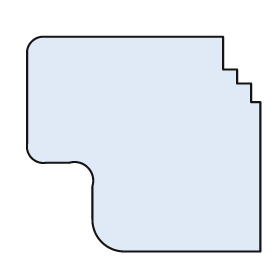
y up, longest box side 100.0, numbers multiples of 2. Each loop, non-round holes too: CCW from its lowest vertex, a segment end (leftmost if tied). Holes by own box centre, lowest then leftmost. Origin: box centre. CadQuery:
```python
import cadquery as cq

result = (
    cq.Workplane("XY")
    .moveTo(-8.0, -46.0)
    .lineTo(50.0, -46.0)
    .lineTo(50.0, 18.0)
    .lineTo(46.0, 18.0)
    .lineTo(46.0, 26.0)
    .lineTo(40.0, 26.0)
    .lineTo(40.0, 32.0)
    .lineTo(34.0, 32.0)
    .lineTo(34.0, 46.0)
    .lineTo(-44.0, 46.0)
    .threePointArc((-48.0, 44.0), (-50.0, 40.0))
    .lineTo(-50.0, 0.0)
    .threePointArc((-48.0, -6.0), (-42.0, -8.0))
    .lineTo(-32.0, -8.0)
    .threePointArc((-24.0, -10.0), (-22.0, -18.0))
    .lineTo(-22.0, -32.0)
    .threePointArc((-18.0, -42.0), (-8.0, -46.0))
    .close()
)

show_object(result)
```